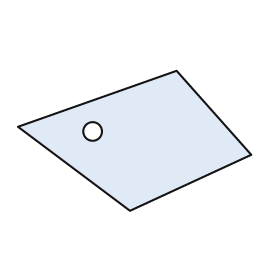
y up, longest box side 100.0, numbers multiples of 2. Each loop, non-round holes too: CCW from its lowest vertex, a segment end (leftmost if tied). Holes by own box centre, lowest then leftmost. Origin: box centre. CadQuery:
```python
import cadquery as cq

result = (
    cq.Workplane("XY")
    .moveTo(-2.0, -30.0)
    .lineTo(50.0, -6.0)
    .lineTo(18.0, 30.0)
    .lineTo(-50.0, 6.0)
    .close()
    .moveTo(-18.0, 4.0)
    .circle(4.0)
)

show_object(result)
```